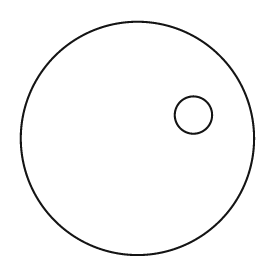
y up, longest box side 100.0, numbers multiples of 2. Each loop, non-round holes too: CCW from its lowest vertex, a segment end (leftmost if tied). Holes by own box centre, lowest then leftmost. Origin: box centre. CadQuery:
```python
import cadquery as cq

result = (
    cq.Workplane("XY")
    .moveTo(0.0, 0.0)
    .circle(50.0)
    .moveTo(24.0, 10.0)
    .circle(8.0)
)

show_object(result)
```